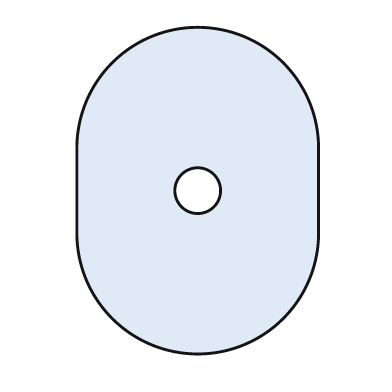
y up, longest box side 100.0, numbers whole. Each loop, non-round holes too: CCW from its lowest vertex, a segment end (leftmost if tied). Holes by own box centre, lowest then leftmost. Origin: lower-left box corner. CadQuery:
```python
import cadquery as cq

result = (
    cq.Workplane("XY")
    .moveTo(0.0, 37.0)
    .threePointArc((37.0, 0.0), (74.0, 37.0))
    .lineTo(74.0, 63.0)
    .threePointArc((37.0, 100.0), (0.0, 63.0))
    .close()
    .moveTo(37.0, 50.0)
    .circle(7.0)
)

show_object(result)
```